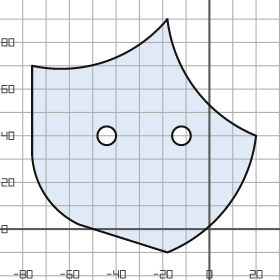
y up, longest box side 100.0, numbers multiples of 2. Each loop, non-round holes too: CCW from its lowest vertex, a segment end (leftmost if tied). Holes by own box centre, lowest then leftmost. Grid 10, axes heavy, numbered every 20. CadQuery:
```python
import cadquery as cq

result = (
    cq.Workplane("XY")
    .moveTo(-18.0, -10.0)
    .threePointArc((8.0, 10.0), (20.0, 40.0))
    .threePointArc((-6.0, 60.0), (-18.0, 90.0))
    .threePointArc((-44.0, 72.0), (-76.0, 70.0))
    .lineTo(-76.0, 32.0)
    .threePointArc((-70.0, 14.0), (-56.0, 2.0))
    .close()
    .moveTo(-44.0, 40.0)
    .circle(4.0)
    .moveTo(-12.0, 40.0)
    .circle(4.0)
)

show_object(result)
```